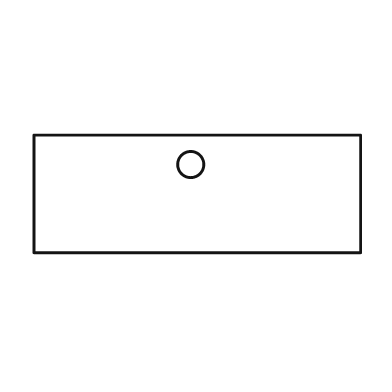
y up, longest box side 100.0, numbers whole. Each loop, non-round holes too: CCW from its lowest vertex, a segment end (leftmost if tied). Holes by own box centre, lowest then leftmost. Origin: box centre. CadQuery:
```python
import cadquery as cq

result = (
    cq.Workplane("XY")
    .moveTo(-50.0, -18.0)
    .lineTo(50.0, -18.0)
    .lineTo(50.0, 18.0)
    .lineTo(-50.0, 18.0)
    .close()
    .moveTo(-2.0, 9.0)
    .circle(4.0)
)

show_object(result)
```